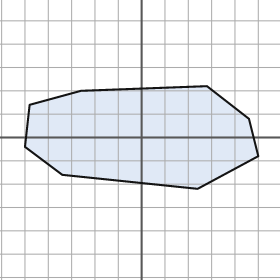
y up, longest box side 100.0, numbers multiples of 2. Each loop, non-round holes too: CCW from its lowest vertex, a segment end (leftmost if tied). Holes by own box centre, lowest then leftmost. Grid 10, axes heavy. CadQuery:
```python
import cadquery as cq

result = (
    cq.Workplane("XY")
    .moveTo(24.0, -22.0)
    .lineTo(50.0, -8.0)
    .lineTo(46.0, 8.0)
    .lineTo(28.0, 22.0)
    .lineTo(-26.0, 20.0)
    .lineTo(-48.0, 14.0)
    .lineTo(-50.0, -4.0)
    .lineTo(-34.0, -16.0)
    .close()
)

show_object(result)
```